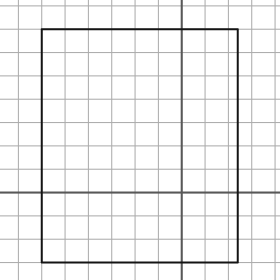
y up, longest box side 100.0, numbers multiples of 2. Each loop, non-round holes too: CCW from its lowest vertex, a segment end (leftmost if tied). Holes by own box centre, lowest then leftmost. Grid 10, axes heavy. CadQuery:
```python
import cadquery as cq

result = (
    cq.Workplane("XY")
    .moveTo(-60.0, -30.0)
    .lineTo(24.0, -30.0)
    .lineTo(24.0, 70.0)
    .lineTo(-60.0, 70.0)
    .close()
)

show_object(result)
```